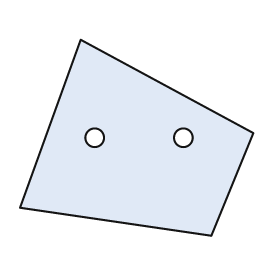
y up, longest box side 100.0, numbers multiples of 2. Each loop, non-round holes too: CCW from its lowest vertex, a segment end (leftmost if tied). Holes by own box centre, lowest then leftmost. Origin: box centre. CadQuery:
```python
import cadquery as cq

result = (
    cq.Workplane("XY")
    .moveTo(32.0, -42.0)
    .lineTo(50.0, 2.0)
    .lineTo(-24.0, 42.0)
    .lineTo(-50.0, -30.0)
    .close()
    .moveTo(-18.0, 0.0)
    .circle(4.0)
    .moveTo(20.0, 0.0)
    .circle(4.0)
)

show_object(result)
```